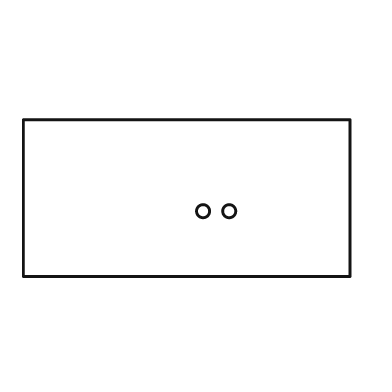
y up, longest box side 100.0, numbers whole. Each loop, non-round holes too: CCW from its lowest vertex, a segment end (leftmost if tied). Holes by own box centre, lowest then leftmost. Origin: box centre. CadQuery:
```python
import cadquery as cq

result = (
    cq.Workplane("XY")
    .moveTo(-50.0, -24.0)
    .lineTo(50.0, -24.0)
    .lineTo(50.0, 24.0)
    .lineTo(-50.0, 24.0)
    .close()
    .moveTo(5.0, -4.0)
    .circle(2.0)
    .moveTo(13.0, -4.0)
    .circle(2.0)
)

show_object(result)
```